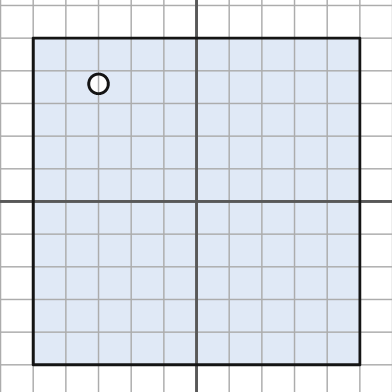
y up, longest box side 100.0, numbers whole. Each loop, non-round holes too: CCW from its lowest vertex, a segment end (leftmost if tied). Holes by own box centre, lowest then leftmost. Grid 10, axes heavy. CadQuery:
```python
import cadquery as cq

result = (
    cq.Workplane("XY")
    .moveTo(-50.0, -50.0)
    .lineTo(50.0, -50.0)
    .lineTo(50.0, 50.0)
    .lineTo(-50.0, 50.0)
    .close()
    .moveTo(-30.0, 36.0)
    .circle(3.0)
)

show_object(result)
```